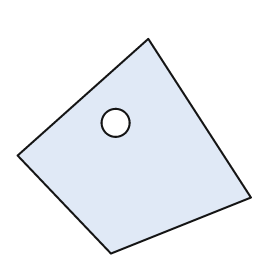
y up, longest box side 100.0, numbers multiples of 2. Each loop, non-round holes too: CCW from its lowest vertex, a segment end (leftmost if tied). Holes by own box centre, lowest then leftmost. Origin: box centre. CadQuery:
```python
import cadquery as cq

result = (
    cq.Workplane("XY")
    .moveTo(-10.0, -46.0)
    .lineTo(50.0, -22.0)
    .lineTo(6.0, 46.0)
    .lineTo(-50.0, -4.0)
    .close()
    .moveTo(-8.0, 10.0)
    .circle(6.0)
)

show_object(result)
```